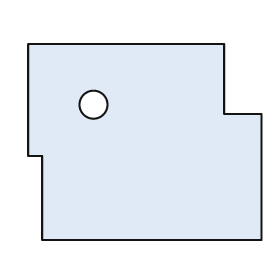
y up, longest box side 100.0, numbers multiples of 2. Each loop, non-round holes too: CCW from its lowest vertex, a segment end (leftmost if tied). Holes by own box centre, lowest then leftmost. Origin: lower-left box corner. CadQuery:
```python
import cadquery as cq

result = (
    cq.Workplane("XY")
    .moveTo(6.0, 0.0)
    .lineTo(100.0, 0.0)
    .lineTo(100.0, 54.0)
    .lineTo(84.0, 54.0)
    .lineTo(84.0, 84.0)
    .lineTo(0.0, 84.0)
    .lineTo(0.0, 36.0)
    .lineTo(6.0, 36.0)
    .close()
    .moveTo(28.0, 58.0)
    .circle(6.0)
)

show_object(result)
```